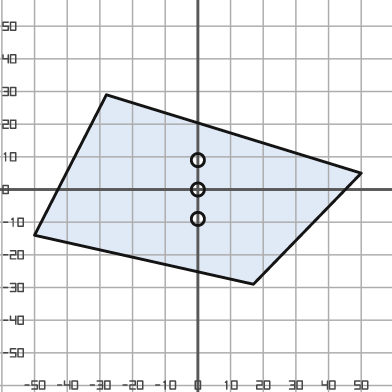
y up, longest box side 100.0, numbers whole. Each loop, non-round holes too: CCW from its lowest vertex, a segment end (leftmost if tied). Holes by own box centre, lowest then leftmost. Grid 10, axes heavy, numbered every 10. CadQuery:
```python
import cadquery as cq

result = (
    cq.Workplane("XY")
    .moveTo(17.0, -29.0)
    .lineTo(50.0, 5.0)
    .lineTo(-28.0, 29.0)
    .lineTo(-50.0, -14.0)
    .close()
    .moveTo(0.0, -9.0)
    .circle(2.0)
    .moveTo(0.0, 0.0)
    .circle(2.0)
    .moveTo(0.0, 9.0)
    .circle(2.0)
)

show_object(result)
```